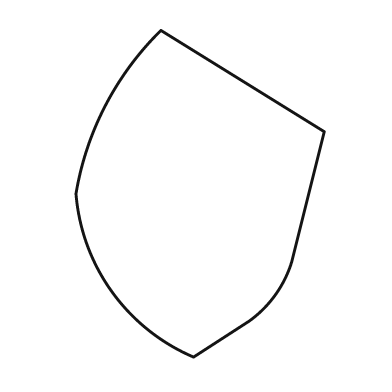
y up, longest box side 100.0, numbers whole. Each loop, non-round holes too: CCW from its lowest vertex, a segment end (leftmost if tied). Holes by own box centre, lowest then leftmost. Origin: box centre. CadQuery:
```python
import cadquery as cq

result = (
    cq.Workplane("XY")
    .moveTo(-2.0, -50.0)
    .lineTo(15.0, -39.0)
    .threePointArc((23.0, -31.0), (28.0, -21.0))
    .lineTo(38.0, 19.0)
    .lineTo(-12.0, 50.0)
    .threePointArc((-29.0, 27.0), (-38.0, 0.0))
    .threePointArc((-27.0, -30.0), (-2.0, -50.0))
    .close()
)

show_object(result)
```